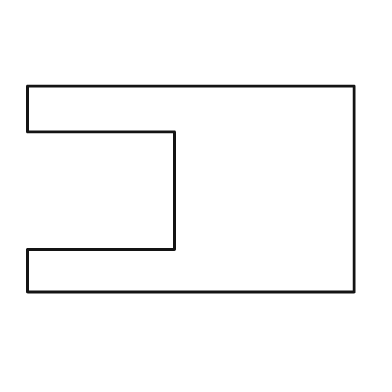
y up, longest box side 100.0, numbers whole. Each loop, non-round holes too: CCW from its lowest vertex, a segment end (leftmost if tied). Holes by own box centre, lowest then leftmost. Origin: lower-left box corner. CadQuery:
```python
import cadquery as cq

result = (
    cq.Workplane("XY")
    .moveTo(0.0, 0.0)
    .lineTo(100.0, 0.0)
    .lineTo(100.0, 63.0)
    .lineTo(0.0, 63.0)
    .lineTo(0.0, 49.0)
    .lineTo(45.0, 49.0)
    .lineTo(45.0, 13.0)
    .lineTo(0.0, 13.0)
    .close()
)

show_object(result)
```